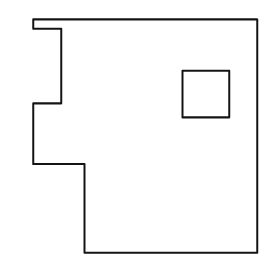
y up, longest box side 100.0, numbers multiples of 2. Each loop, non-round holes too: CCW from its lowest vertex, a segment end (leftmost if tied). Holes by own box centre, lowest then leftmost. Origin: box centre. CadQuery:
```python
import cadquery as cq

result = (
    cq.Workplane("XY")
    .moveTo(-26.0, -50.0)
    .lineTo(48.0, -50.0)
    .lineTo(48.0, 50.0)
    .lineTo(-48.0, 50.0)
    .lineTo(-48.0, 46.0)
    .lineTo(-36.0, 46.0)
    .lineTo(-36.0, 14.0)
    .lineTo(-48.0, 14.0)
    .lineTo(-48.0, -12.0)
    .lineTo(-26.0, -12.0)
    .close()
    .moveTo(16.0, 8.0)
    .lineTo(36.0, 8.0)
    .lineTo(36.0, 28.0)
    .lineTo(16.0, 28.0)
    .close()
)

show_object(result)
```